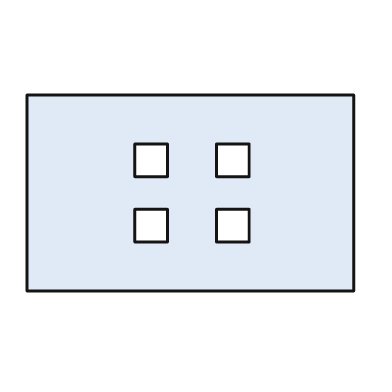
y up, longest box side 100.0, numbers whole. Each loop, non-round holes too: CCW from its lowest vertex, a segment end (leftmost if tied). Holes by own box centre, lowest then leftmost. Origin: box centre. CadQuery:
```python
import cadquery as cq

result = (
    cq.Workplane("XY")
    .moveTo(-50.0, -30.0)
    .lineTo(50.0, -30.0)
    .lineTo(50.0, 30.0)
    .lineTo(-50.0, 30.0)
    .close()
    .moveTo(-17.0, -15.0)
    .lineTo(-7.0, -15.0)
    .lineTo(-7.0, -5.0)
    .lineTo(-17.0, -5.0)
    .close()
    .moveTo(8.0, -15.0)
    .lineTo(18.0, -15.0)
    .lineTo(18.0, -5.0)
    .lineTo(8.0, -5.0)
    .close()
    .moveTo(-17.0, 5.0)
    .lineTo(-7.0, 5.0)
    .lineTo(-7.0, 15.0)
    .lineTo(-17.0, 15.0)
    .close()
    .moveTo(8.0, 5.0)
    .lineTo(18.0, 5.0)
    .lineTo(18.0, 15.0)
    .lineTo(8.0, 15.0)
    .close()
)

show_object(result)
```